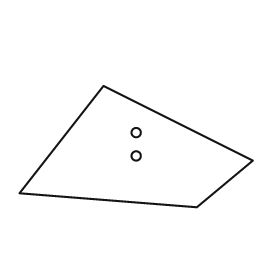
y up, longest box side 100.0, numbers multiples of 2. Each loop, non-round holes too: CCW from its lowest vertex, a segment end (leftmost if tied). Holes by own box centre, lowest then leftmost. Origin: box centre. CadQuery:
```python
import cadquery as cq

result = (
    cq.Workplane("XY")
    .moveTo(26.0, -26.0)
    .lineTo(50.0, -6.0)
    .lineTo(-14.0, 26.0)
    .lineTo(-50.0, -20.0)
    .close()
    .moveTo(0.0, -4.0)
    .circle(2.0)
    .moveTo(0.0, 6.0)
    .circle(2.0)
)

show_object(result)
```